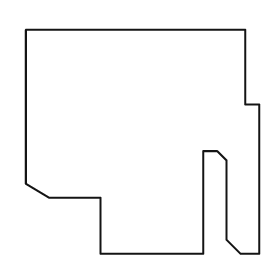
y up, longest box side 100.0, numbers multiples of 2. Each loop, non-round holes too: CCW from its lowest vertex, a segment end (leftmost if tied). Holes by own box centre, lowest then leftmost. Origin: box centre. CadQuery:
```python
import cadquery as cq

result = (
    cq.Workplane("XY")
    .moveTo(-18.0, -48.0)
    .lineTo(26.0, -48.0)
    .lineTo(26.0, -4.0)
    .lineTo(32.0, -4.0)
    .lineTo(36.0, -8.0)
    .lineTo(36.0, -42.0)
    .lineTo(42.0, -48.0)
    .lineTo(50.0, -48.0)
    .lineTo(50.0, 16.0)
    .lineTo(44.0, 16.0)
    .lineTo(44.0, 48.0)
    .lineTo(-50.0, 48.0)
    .lineTo(-50.0, -18.0)
    .lineTo(-40.0, -24.0)
    .lineTo(-18.0, -24.0)
    .close()
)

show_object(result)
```